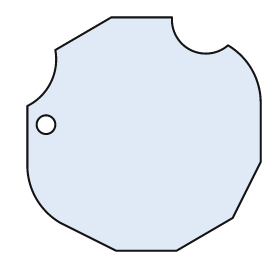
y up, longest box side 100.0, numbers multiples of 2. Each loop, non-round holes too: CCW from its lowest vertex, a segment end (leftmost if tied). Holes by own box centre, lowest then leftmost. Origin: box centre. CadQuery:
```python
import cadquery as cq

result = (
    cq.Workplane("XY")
    .moveTo(-12.0, -50.0)
    .lineTo(14.0, -50.0)
    .lineTo(38.0, -36.0)
    .lineTo(50.0, -12.0)
    .lineTo(50.0, 14.0)
    .threePointArc((46.0, 28.0), (36.0, 38.0))
    .threePointArc((20.0, 36.0), (12.0, 50.0))
    .lineTo(-14.0, 50.0)
    .lineTo(-38.0, 36.0)
    .threePointArc((-40.0, 22.0), (-50.0, 12.0))
    .lineTo(-50.0, -14.0)
    .threePointArc((-46.0, -28.0), (-36.0, -38.0))
    .close()
    .moveTo(-42.0, 4.0)
    .circle(4.0)
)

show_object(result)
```